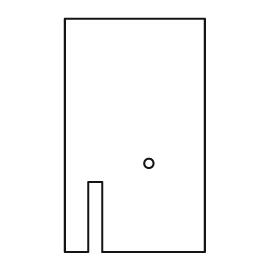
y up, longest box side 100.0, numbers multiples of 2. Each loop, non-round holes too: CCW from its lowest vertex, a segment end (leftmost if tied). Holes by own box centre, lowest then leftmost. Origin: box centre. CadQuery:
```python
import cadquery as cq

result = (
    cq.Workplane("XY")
    .moveTo(-30.0, -50.0)
    .lineTo(-20.0, -50.0)
    .lineTo(-20.0, -20.0)
    .lineTo(-14.0, -20.0)
    .lineTo(-14.0, -50.0)
    .lineTo(30.0, -50.0)
    .lineTo(30.0, 50.0)
    .lineTo(-30.0, 50.0)
    .close()
    .moveTo(6.0, -12.0)
    .circle(2.0)
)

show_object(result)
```